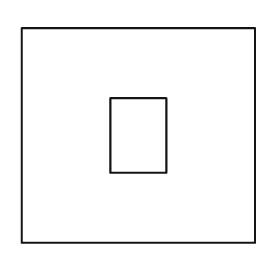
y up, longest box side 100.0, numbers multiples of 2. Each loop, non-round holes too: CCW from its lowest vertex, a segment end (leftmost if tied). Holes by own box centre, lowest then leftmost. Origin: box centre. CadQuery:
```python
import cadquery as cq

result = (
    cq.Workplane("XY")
    .moveTo(-50.0, -46.0)
    .lineTo(50.0, -46.0)
    .lineTo(50.0, 46.0)
    .lineTo(-50.0, 46.0)
    .close()
    .moveTo(-12.0, -16.0)
    .lineTo(12.0, -16.0)
    .lineTo(12.0, 16.0)
    .lineTo(-12.0, 16.0)
    .close()
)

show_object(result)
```